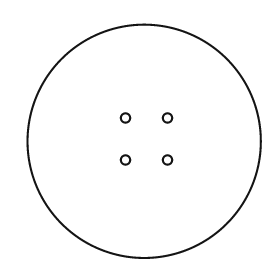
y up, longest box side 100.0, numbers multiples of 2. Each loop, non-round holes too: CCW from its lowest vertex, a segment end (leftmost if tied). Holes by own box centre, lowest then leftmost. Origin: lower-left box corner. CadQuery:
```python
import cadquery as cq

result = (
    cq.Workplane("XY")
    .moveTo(50.0, 50.0)
    .circle(50.0)
    .moveTo(42.0, 42.0)
    .circle(2.0)
    .moveTo(60.0, 42.0)
    .circle(2.0)
    .moveTo(42.0, 60.0)
    .circle(2.0)
    .moveTo(60.0, 60.0)
    .circle(2.0)
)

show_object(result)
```